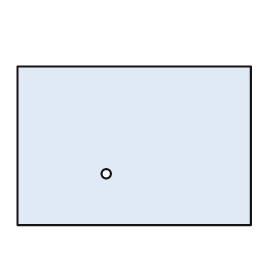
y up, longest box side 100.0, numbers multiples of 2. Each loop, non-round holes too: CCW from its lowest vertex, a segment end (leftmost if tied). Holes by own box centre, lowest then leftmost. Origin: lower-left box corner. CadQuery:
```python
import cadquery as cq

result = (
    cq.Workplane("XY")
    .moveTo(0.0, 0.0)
    .lineTo(100.0, 0.0)
    .lineTo(100.0, 68.0)
    .lineTo(0.0, 68.0)
    .close()
    .moveTo(38.0, 22.0)
    .circle(2.0)
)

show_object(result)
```